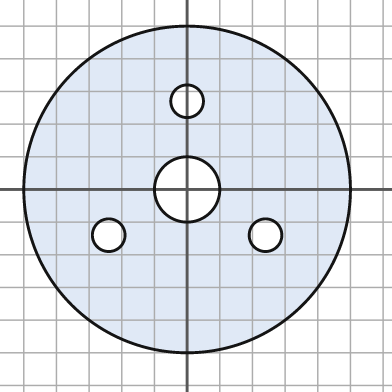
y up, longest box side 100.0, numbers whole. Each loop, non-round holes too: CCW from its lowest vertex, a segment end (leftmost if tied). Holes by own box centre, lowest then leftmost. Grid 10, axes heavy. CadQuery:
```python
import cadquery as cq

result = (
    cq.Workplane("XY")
    .moveTo(0.0, 0.0)
    .circle(50.0)
    .moveTo(-24.0, -14.0)
    .circle(5.0)
    .moveTo(24.0, -14.0)
    .circle(5.0)
    .moveTo(0.0, 0.0)
    .circle(10.0)
    .moveTo(0.0, 27.0)
    .circle(5.0)
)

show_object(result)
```